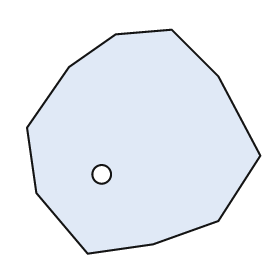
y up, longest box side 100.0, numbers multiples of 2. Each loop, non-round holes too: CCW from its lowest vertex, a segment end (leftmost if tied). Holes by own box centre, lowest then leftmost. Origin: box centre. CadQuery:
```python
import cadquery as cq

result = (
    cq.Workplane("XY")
    .moveTo(-24.0, -48.0)
    .lineTo(4.0, -44.0)
    .lineTo(32.0, -34.0)
    .lineTo(50.0, -6.0)
    .lineTo(32.0, 28.0)
    .lineTo(12.0, 48.0)
    .lineTo(-12.0, 46.0)
    .lineTo(-32.0, 32.0)
    .lineTo(-50.0, 6.0)
    .lineTo(-46.0, -22.0)
    .close()
    .moveTo(-18.0, -14.0)
    .circle(4.0)
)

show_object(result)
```